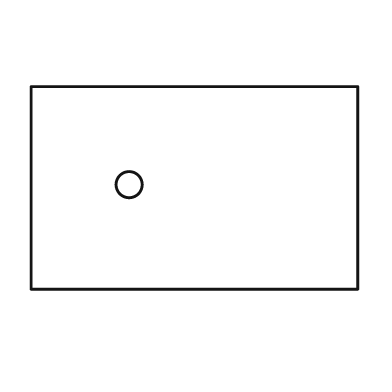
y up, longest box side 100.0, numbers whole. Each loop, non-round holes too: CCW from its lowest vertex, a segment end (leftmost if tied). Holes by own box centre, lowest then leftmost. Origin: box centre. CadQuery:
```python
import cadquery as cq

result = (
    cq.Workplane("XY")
    .moveTo(-50.0, -31.0)
    .lineTo(50.0, -31.0)
    .lineTo(50.0, 31.0)
    .lineTo(-50.0, 31.0)
    .close()
    .moveTo(-20.0, 1.0)
    .circle(4.0)
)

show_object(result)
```